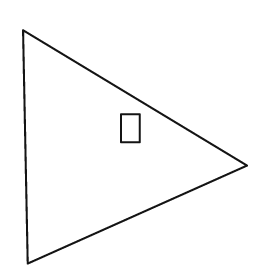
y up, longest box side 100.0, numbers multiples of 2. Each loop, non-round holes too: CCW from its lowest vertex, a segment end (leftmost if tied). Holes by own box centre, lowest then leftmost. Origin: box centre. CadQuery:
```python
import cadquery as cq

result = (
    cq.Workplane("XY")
    .moveTo(-46.0, -50.0)
    .lineTo(48.0, -8.0)
    .lineTo(-48.0, 50.0)
    .close()
    .moveTo(-6.0, 2.0)
    .lineTo(2.0, 2.0)
    .lineTo(2.0, 14.0)
    .lineTo(-6.0, 14.0)
    .close()
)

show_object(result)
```